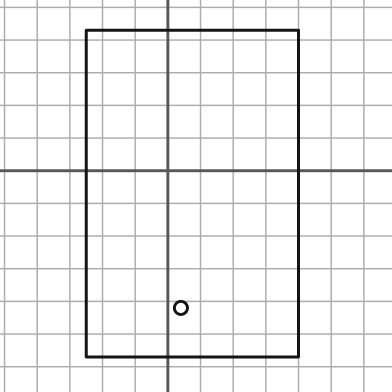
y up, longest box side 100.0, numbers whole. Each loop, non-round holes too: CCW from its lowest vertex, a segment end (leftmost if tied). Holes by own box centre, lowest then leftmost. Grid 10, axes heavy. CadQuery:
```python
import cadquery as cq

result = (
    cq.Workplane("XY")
    .moveTo(-25.0, -57.0)
    .lineTo(40.0, -57.0)
    .lineTo(40.0, 43.0)
    .lineTo(-25.0, 43.0)
    .close()
    .moveTo(4.0, -42.0)
    .circle(2.0)
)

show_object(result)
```